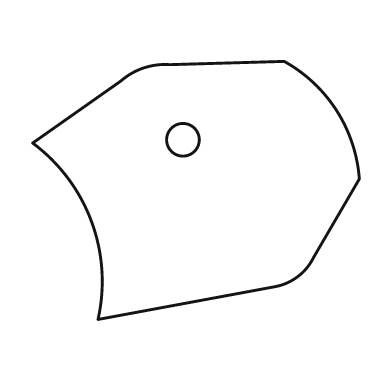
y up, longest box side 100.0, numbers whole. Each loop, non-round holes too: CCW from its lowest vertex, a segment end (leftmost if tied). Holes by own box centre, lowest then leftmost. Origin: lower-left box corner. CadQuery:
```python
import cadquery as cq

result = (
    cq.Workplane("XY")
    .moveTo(20.0, 0.0)
    .lineTo(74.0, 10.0)
    .threePointArc((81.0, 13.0), (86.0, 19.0))
    .lineTo(100.0, 43.0)
    .threePointArc((93.0, 64.0), (77.0, 79.0))
    .lineTo(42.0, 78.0)
    .threePointArc((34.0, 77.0), (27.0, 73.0))
    .lineTo(0.0, 54.0)
    .threePointArc((18.0, 30.0), (20.0, 0.0))
    .close()
    .moveTo(46.0, 55.0)
    .circle(5.0)
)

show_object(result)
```